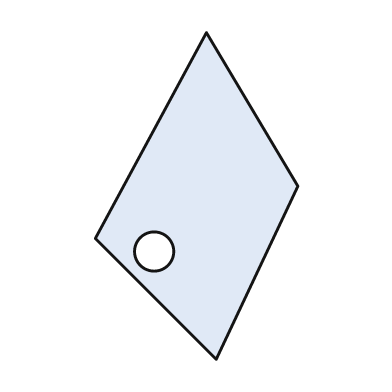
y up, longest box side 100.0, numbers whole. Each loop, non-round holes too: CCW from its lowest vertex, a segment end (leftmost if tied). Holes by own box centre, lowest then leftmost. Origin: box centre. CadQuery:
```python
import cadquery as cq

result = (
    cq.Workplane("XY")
    .moveTo(6.0, -50.0)
    .lineTo(31.0, 3.0)
    .lineTo(3.0, 50.0)
    .lineTo(-31.0, -13.0)
    .close()
    .moveTo(-13.0, -17.0)
    .circle(6.0)
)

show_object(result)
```